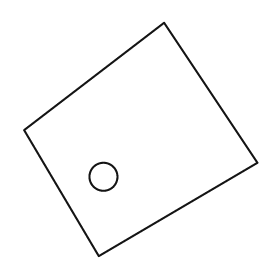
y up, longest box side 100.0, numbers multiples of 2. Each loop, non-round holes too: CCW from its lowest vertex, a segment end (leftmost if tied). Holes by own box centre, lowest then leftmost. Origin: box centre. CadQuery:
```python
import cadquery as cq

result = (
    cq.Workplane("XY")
    .moveTo(-18.0, -50.0)
    .lineTo(50.0, -10.0)
    .lineTo(10.0, 50.0)
    .lineTo(-50.0, 4.0)
    .close()
    .moveTo(-16.0, -16.0)
    .circle(6.0)
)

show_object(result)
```